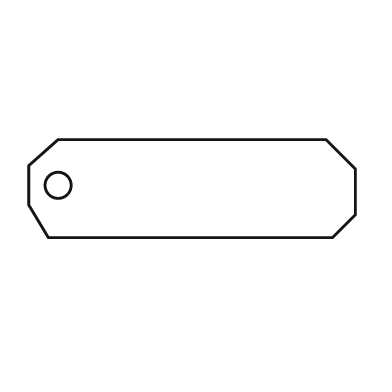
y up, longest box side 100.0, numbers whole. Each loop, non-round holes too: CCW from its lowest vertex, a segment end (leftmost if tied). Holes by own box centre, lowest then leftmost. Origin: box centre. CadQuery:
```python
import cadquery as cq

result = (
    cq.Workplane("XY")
    .moveTo(-44.0, -15.0)
    .lineTo(43.0, -15.0)
    .lineTo(50.0, -8.0)
    .lineTo(50.0, 6.0)
    .lineTo(41.0, 15.0)
    .lineTo(-41.0, 15.0)
    .lineTo(-50.0, 7.0)
    .lineTo(-50.0, -5.0)
    .close()
    .moveTo(-41.0, 1.0)
    .circle(4.0)
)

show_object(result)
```